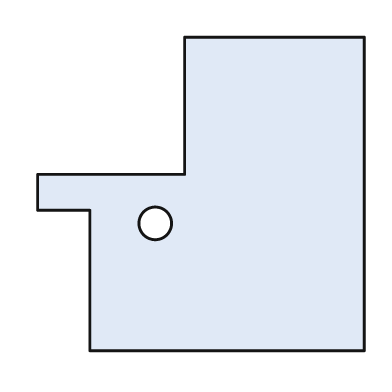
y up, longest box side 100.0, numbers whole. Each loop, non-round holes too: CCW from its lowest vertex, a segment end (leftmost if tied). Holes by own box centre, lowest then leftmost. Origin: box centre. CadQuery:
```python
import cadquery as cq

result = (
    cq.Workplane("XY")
    .moveTo(-34.0, -48.0)
    .lineTo(50.0, -48.0)
    .lineTo(50.0, 48.0)
    .lineTo(-5.0, 48.0)
    .lineTo(-5.0, 6.0)
    .lineTo(-50.0, 6.0)
    .lineTo(-50.0, -5.0)
    .lineTo(-34.0, -5.0)
    .close()
    .moveTo(-14.0, -9.0)
    .circle(5.0)
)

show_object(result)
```